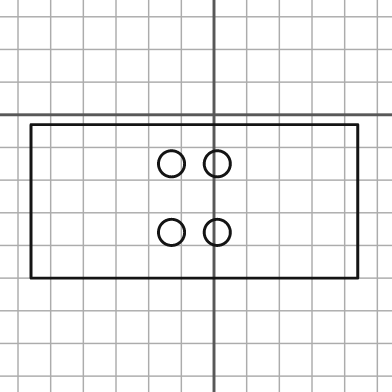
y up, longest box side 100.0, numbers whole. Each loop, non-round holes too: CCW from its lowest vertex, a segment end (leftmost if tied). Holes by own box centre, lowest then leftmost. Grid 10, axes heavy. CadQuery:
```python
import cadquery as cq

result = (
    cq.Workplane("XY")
    .moveTo(-56.0, -50.0)
    .lineTo(44.0, -50.0)
    .lineTo(44.0, -3.0)
    .lineTo(-56.0, -3.0)
    .close()
    .moveTo(-13.0, -36.0)
    .circle(4.0)
    .moveTo(1.0, -36.0)
    .circle(4.0)
    .moveTo(-13.0, -15.0)
    .circle(4.0)
    .moveTo(1.0, -15.0)
    .circle(4.0)
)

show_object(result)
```